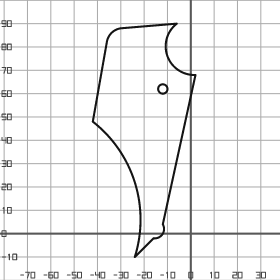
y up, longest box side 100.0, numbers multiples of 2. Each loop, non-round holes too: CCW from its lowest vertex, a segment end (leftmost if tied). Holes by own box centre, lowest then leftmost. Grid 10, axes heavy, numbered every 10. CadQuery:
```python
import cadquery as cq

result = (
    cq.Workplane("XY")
    .moveTo(-24.0, -10.0)
    .lineTo(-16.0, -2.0)
    .threePointArc((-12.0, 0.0), (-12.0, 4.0))
    .lineTo(2.0, 68.0)
    .threePointArc((-10.0, 76.0), (-6.0, 90.0))
    .lineTo(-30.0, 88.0)
    .threePointArc((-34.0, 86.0), (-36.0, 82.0))
    .lineTo(-42.0, 48.0)
    .threePointArc((-24.0, 22.0), (-24.0, -10.0))
    .close()
    .moveTo(-12.0, 62.0)
    .circle(2.0)
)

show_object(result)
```